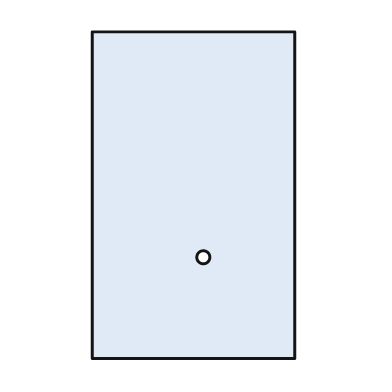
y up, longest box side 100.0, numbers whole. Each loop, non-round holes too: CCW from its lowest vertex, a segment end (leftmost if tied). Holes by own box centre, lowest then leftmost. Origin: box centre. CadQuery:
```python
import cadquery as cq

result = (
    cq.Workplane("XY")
    .moveTo(-31.0, -50.0)
    .lineTo(31.0, -50.0)
    .lineTo(31.0, 50.0)
    .lineTo(-31.0, 50.0)
    .close()
    .moveTo(3.0, -19.0)
    .circle(2.0)
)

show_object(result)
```